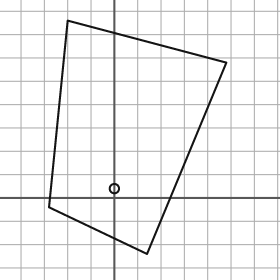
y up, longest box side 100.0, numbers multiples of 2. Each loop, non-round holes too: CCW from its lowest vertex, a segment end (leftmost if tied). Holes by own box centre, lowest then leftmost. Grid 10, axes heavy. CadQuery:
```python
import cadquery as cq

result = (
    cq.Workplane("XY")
    .moveTo(14.0, -24.0)
    .lineTo(48.0, 58.0)
    .lineTo(-20.0, 76.0)
    .lineTo(-28.0, -4.0)
    .close()
    .moveTo(0.0, 4.0)
    .circle(2.0)
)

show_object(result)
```